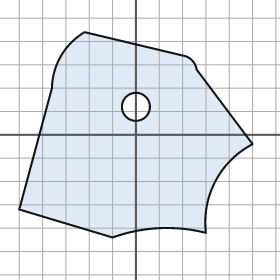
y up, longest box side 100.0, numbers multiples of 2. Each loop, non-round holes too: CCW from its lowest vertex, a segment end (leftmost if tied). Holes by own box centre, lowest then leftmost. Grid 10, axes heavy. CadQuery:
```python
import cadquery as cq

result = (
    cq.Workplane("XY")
    .moveTo(-10.0, -44.0)
    .threePointArc((10.0, -40.0), (30.0, -42.0))
    .threePointArc((34.0, -20.0), (50.0, -4.0))
    .lineTo(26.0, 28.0)
    .threePointArc((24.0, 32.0), (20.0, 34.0))
    .lineTo(-22.0, 44.0)
    .threePointArc((-32.0, 34.0), (-36.0, 20.0))
    .lineTo(-50.0, -32.0)
    .close()
    .moveTo(0.0, 12.0)
    .circle(6.0)
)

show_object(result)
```